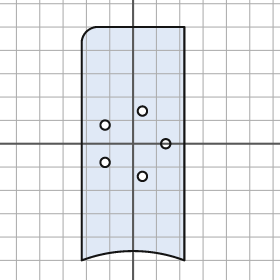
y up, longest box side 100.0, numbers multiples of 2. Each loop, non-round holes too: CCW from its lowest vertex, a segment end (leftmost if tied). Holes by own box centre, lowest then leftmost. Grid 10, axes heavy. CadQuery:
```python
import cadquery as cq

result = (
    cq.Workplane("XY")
    .moveTo(-22.0, -50.0)
    .threePointArc((0.0, -46.0), (22.0, -50.0))
    .lineTo(22.0, 50.0)
    .lineTo(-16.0, 50.0)
    .threePointArc((-20.0, 48.0), (-22.0, 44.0))
    .close()
    .moveTo(4.0, -14.0)
    .circle(2.0)
    .moveTo(-12.0, -8.0)
    .circle(2.0)
    .moveTo(14.0, 0.0)
    .circle(2.0)
    .moveTo(-12.0, 8.0)
    .circle(2.0)
    .moveTo(4.0, 14.0)
    .circle(2.0)
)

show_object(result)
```